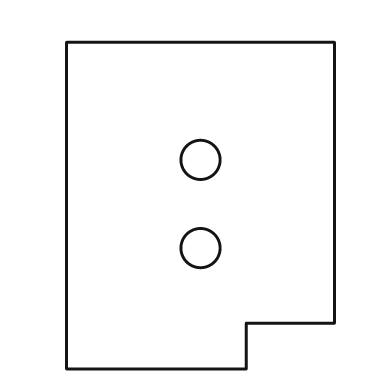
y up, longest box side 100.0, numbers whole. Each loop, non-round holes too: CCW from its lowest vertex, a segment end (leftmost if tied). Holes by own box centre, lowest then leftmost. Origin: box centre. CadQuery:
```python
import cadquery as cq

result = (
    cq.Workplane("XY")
    .moveTo(-41.0, -50.0)
    .lineTo(14.0, -50.0)
    .lineTo(14.0, -36.0)
    .lineTo(41.0, -36.0)
    .lineTo(41.0, 50.0)
    .lineTo(-41.0, 50.0)
    .close()
    .moveTo(0.0, -13.0)
    .circle(6.0)
    .moveTo(0.0, 14.0)
    .circle(6.0)
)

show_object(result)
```